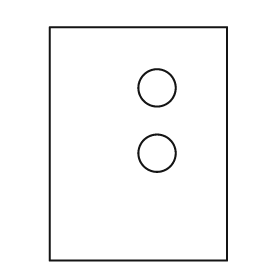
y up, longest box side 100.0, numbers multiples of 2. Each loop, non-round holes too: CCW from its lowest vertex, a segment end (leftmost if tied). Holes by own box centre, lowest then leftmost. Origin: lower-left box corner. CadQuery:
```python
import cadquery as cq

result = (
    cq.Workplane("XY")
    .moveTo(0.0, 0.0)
    .lineTo(76.0, 0.0)
    .lineTo(76.0, 100.0)
    .lineTo(0.0, 100.0)
    .close()
    .moveTo(46.0, 46.0)
    .circle(8.0)
    .moveTo(46.0, 74.0)
    .circle(8.0)
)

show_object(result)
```